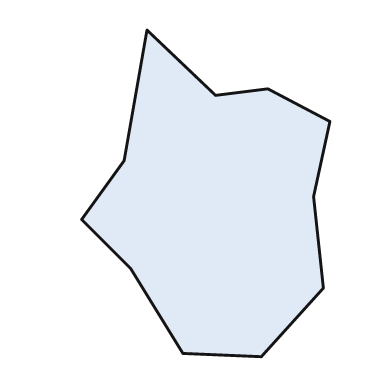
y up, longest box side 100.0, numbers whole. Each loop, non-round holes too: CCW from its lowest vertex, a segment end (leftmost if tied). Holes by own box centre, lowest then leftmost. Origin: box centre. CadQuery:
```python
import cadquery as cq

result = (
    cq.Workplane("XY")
    .moveTo(17.0, -50.0)
    .lineTo(36.0, -29.0)
    .lineTo(33.0, -1.0)
    .lineTo(38.0, 22.0)
    .lineTo(19.0, 32.0)
    .lineTo(3.0, 30.0)
    .lineTo(-18.0, 50.0)
    .lineTo(-25.0, 10.0)
    .lineTo(-38.0, -8.0)
    .lineTo(-23.0, -23.0)
    .lineTo(-7.0, -49.0)
    .close()
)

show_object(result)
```